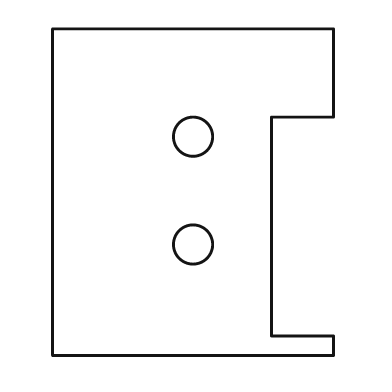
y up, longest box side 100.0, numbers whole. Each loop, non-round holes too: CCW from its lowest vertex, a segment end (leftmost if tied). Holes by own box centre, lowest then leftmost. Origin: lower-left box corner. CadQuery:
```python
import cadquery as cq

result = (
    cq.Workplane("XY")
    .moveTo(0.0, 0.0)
    .lineTo(86.0, 0.0)
    .lineTo(86.0, 6.0)
    .lineTo(67.0, 6.0)
    .lineTo(67.0, 73.0)
    .lineTo(86.0, 73.0)
    .lineTo(86.0, 100.0)
    .lineTo(0.0, 100.0)
    .close()
    .moveTo(43.0, 34.0)
    .circle(6.0)
    .moveTo(43.0, 67.0)
    .circle(6.0)
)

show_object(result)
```